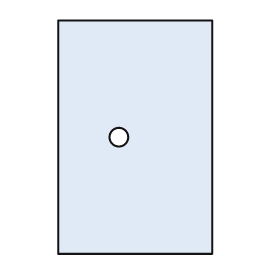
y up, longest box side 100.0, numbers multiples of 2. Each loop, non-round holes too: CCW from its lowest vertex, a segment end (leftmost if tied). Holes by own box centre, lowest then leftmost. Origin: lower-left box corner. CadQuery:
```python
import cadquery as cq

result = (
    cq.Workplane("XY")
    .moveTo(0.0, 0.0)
    .lineTo(66.0, 0.0)
    .lineTo(66.0, 100.0)
    .lineTo(0.0, 100.0)
    .close()
    .moveTo(26.0, 50.0)
    .circle(4.0)
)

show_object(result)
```